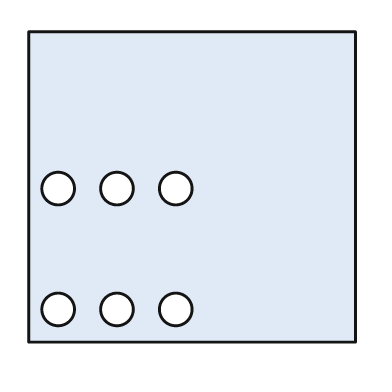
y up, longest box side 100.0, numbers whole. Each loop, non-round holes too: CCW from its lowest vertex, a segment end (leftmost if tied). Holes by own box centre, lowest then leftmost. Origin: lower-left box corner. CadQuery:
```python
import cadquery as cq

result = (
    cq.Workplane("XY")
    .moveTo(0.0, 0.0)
    .lineTo(100.0, 0.0)
    .lineTo(100.0, 95.0)
    .lineTo(0.0, 95.0)
    .close()
    .moveTo(9.0, 10.0)
    .circle(5.0)
    .moveTo(27.0, 10.0)
    .circle(5.0)
    .moveTo(45.0, 10.0)
    .circle(5.0)
    .moveTo(9.0, 47.0)
    .circle(5.0)
    .moveTo(27.0, 47.0)
    .circle(5.0)
    .moveTo(45.0, 47.0)
    .circle(5.0)
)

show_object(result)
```